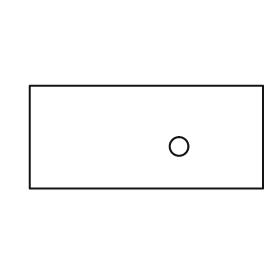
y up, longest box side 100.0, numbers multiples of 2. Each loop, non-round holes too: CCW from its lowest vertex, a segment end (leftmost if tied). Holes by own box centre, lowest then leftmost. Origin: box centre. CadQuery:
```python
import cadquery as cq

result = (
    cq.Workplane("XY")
    .moveTo(-50.0, -22.0)
    .lineTo(50.0, -22.0)
    .lineTo(50.0, 22.0)
    .lineTo(-50.0, 22.0)
    .close()
    .moveTo(14.0, -4.0)
    .circle(4.0)
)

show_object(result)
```